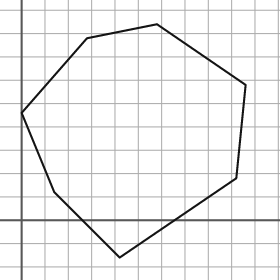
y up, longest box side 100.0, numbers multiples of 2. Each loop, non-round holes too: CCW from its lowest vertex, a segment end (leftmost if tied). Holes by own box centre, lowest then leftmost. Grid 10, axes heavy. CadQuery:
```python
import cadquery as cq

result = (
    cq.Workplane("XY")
    .moveTo(42.0, -16.0)
    .lineTo(92.0, 18.0)
    .lineTo(96.0, 58.0)
    .lineTo(58.0, 84.0)
    .lineTo(28.0, 78.0)
    .lineTo(0.0, 46.0)
    .lineTo(14.0, 12.0)
    .close()
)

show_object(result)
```